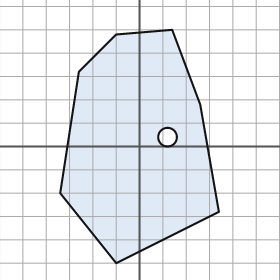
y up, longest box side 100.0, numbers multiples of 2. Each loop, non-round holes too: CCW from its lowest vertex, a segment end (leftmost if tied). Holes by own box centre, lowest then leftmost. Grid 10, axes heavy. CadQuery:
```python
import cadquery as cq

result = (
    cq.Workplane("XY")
    .moveTo(-10.0, -50.0)
    .lineTo(34.0, -28.0)
    .lineTo(26.0, 18.0)
    .lineTo(14.0, 50.0)
    .lineTo(-10.0, 48.0)
    .lineTo(-26.0, 32.0)
    .lineTo(-34.0, -20.0)
    .close()
    .moveTo(12.0, 4.0)
    .circle(4.0)
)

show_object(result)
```